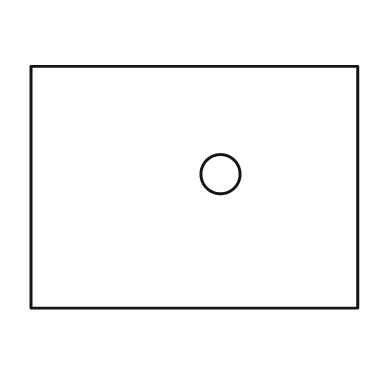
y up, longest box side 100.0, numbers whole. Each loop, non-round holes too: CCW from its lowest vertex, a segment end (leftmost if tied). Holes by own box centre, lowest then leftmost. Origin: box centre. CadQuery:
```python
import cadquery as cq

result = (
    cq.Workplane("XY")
    .moveTo(-50.0, -37.0)
    .lineTo(50.0, -37.0)
    .lineTo(50.0, 37.0)
    .lineTo(-50.0, 37.0)
    .close()
    .moveTo(8.0, 4.0)
    .circle(6.0)
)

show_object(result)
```